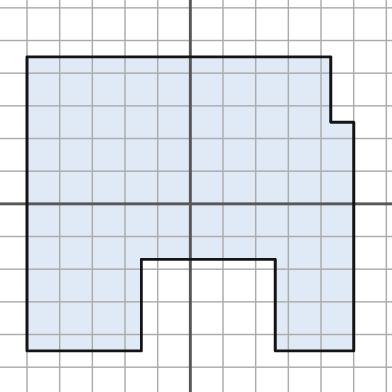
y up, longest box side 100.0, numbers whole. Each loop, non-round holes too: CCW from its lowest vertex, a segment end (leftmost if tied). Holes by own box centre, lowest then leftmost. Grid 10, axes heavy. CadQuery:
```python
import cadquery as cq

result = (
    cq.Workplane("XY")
    .moveTo(-50.0, -45.0)
    .lineTo(-15.0, -45.0)
    .lineTo(-15.0, -17.0)
    .lineTo(26.0, -17.0)
    .lineTo(26.0, -45.0)
    .lineTo(50.0, -45.0)
    .lineTo(50.0, 25.0)
    .lineTo(43.0, 25.0)
    .lineTo(43.0, 45.0)
    .lineTo(-50.0, 45.0)
    .close()
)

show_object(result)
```